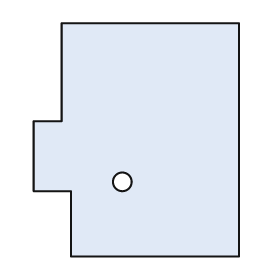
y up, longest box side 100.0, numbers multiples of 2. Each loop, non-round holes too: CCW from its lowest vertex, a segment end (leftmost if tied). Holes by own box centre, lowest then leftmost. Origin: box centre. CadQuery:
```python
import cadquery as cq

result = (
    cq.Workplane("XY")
    .moveTo(-28.0, -50.0)
    .lineTo(44.0, -50.0)
    .lineTo(44.0, 50.0)
    .lineTo(-32.0, 50.0)
    .lineTo(-32.0, 8.0)
    .lineTo(-44.0, 8.0)
    .lineTo(-44.0, -22.0)
    .lineTo(-28.0, -22.0)
    .close()
    .moveTo(-6.0, -18.0)
    .circle(4.0)
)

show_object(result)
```